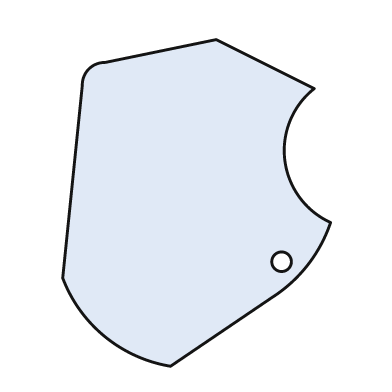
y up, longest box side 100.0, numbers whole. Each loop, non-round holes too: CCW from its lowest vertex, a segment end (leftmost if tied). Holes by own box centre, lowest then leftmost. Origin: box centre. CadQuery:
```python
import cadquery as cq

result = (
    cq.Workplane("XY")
    .moveTo(-8.0, -50.0)
    .lineTo(23.0, -29.0)
    .threePointArc((34.0, -19.0), (41.0, -6.0))
    .threePointArc((27.0, 13.0), (36.0, 35.0))
    .lineTo(6.0, 50.0)
    .lineTo(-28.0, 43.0)
    .threePointArc((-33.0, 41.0), (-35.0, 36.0))
    .lineTo(-41.0, -23.0)
    .threePointArc((-28.0, -41.0), (-8.0, -50.0))
    .close()
    .moveTo(26.0, -18.0)
    .circle(3.0)
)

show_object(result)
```